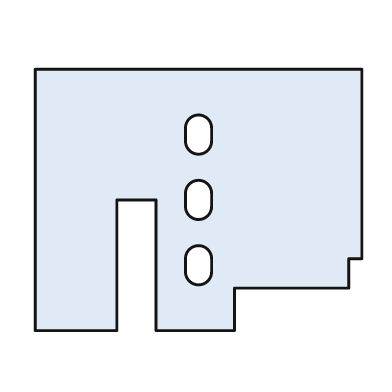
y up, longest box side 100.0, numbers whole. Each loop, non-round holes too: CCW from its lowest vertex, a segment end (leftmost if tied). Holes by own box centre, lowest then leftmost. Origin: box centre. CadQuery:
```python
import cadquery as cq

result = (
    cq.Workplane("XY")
    .moveTo(-50.0, -40.0)
    .lineTo(-25.0, -40.0)
    .lineTo(-25.0, 0.0)
    .lineTo(-13.0, 0.0)
    .lineTo(-13.0, -40.0)
    .lineTo(11.0, -40.0)
    .lineTo(11.0, -27.0)
    .lineTo(46.0, -27.0)
    .lineTo(46.0, -18.0)
    .lineTo(50.0, -18.0)
    .lineTo(50.0, 40.0)
    .lineTo(-50.0, 40.0)
    .close()
    .moveTo(-4.0, -22.0)
    .threePointArc((0.0, -26.0), (4.0, -22.0))
    .lineTo(4.0, -18.0)
    .threePointArc((0.0, -14.0), (-4.0, -18.0))
    .close()
    .moveTo(-4.0, -2.0)
    .threePointArc((0.0, -6.0), (4.0, -2.0))
    .lineTo(4.0, 2.0)
    .threePointArc((0.0, 6.0), (-4.0, 2.0))
    .close()
    .moveTo(-4.0, 18.0)
    .threePointArc((0.0, 14.0), (4.0, 18.0))
    .lineTo(4.0, 22.0)
    .threePointArc((0.0, 26.0), (-4.0, 22.0))
    .close()
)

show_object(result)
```